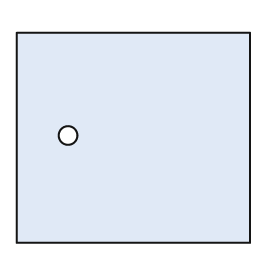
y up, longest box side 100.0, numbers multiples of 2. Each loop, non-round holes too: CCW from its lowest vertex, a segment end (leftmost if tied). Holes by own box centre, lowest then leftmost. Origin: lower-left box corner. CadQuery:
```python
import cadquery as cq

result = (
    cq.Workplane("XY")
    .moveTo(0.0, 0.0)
    .lineTo(100.0, 0.0)
    .lineTo(100.0, 90.0)
    .lineTo(0.0, 90.0)
    .close()
    .moveTo(22.0, 46.0)
    .circle(4.0)
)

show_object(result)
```